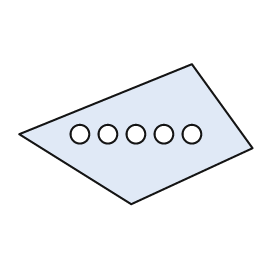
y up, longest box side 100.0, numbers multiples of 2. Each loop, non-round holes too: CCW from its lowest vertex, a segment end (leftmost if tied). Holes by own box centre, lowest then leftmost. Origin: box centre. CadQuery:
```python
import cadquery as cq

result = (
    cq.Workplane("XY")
    .moveTo(-2.0, -30.0)
    .lineTo(50.0, -6.0)
    .lineTo(24.0, 30.0)
    .lineTo(-50.0, 0.0)
    .close()
    .moveTo(-24.0, 0.0)
    .circle(4.0)
    .moveTo(-12.0, 0.0)
    .circle(4.0)
    .moveTo(0.0, 0.0)
    .circle(4.0)
    .moveTo(12.0, 0.0)
    .circle(4.0)
    .moveTo(24.0, 0.0)
    .circle(4.0)
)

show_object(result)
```